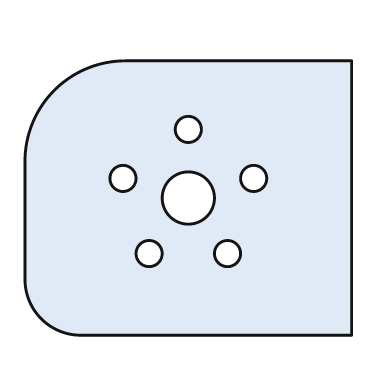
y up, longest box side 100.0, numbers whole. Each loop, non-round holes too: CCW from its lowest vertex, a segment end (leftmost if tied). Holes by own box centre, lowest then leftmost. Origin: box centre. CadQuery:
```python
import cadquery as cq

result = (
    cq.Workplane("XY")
    .moveTo(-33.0, -42.0)
    .lineTo(50.0, -42.0)
    .lineTo(50.0, 42.0)
    .lineTo(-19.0, 42.0)
    .threePointArc((-41.0, 33.0), (-50.0, 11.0))
    .lineTo(-50.0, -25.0)
    .threePointArc((-45.0, -37.0), (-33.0, -42.0))
    .close()
    .moveTo(-12.0, -17.0)
    .circle(4.0)
    .moveTo(12.0, -17.0)
    .circle(4.0)
    .moveTo(0.0, 0.0)
    .circle(8.0)
    .moveTo(-20.0, 6.0)
    .circle(4.0)
    .moveTo(20.0, 6.0)
    .circle(4.0)
    .moveTo(0.0, 21.0)
    .circle(4.0)
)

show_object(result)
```